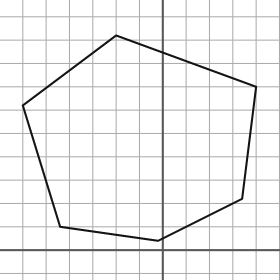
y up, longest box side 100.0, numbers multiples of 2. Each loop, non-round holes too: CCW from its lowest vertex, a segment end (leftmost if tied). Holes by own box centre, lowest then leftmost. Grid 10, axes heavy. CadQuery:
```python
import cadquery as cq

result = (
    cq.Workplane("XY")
    .moveTo(-2.0, 4.0)
    .lineTo(34.0, 22.0)
    .lineTo(40.0, 70.0)
    .lineTo(-20.0, 92.0)
    .lineTo(-60.0, 62.0)
    .lineTo(-44.0, 10.0)
    .close()
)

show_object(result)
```